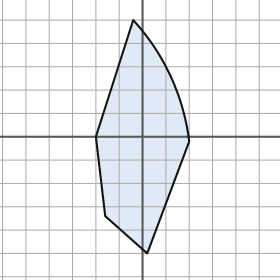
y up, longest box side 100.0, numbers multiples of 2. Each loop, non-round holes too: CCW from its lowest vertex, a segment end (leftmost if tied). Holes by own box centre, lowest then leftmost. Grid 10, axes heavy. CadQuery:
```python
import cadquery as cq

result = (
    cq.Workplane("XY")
    .moveTo(2.0, -50.0)
    .lineTo(20.0, -2.0)
    .threePointArc((12.0, 26.0), (-4.0, 50.0))
    .lineTo(-20.0, 0.0)
    .lineTo(-16.0, -34.0)
    .close()
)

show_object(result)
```